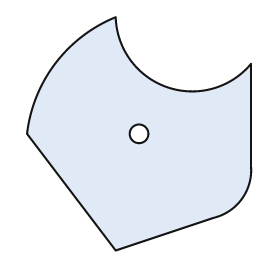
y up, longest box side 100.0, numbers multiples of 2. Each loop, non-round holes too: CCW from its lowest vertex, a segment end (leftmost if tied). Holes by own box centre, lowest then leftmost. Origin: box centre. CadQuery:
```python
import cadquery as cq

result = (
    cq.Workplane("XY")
    .moveTo(-10.0, -50.0)
    .lineTo(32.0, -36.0)
    .threePointArc((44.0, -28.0), (48.0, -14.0))
    .lineTo(48.0, 30.0)
    .threePointArc((12.0, 20.0), (-10.0, 50.0))
    .threePointArc((-36.0, 30.0), (-48.0, 0.0))
    .close()
    .moveTo(0.0, 0.0)
    .circle(4.0)
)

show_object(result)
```